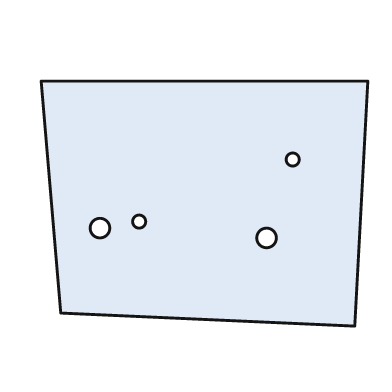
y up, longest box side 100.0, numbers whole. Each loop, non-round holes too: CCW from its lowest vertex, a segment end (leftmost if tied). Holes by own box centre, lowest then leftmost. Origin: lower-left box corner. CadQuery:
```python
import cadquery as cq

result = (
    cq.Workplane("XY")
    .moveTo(96.0, 0.0)
    .lineTo(100.0, 75.0)
    .lineTo(0.0, 75.0)
    .lineTo(6.0, 4.0)
    .close()
    .moveTo(69.0, 27.0)
    .circle(3.0)
    .moveTo(18.0, 30.0)
    .circle(3.0)
    .moveTo(30.0, 32.0)
    .circle(2.0)
    .moveTo(77.0, 51.0)
    .circle(2.0)
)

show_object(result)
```